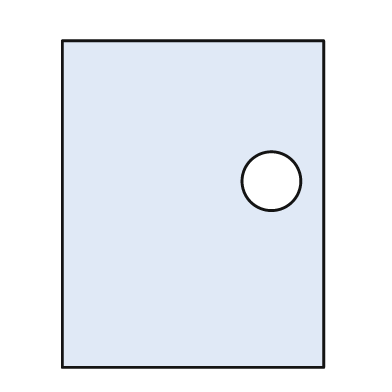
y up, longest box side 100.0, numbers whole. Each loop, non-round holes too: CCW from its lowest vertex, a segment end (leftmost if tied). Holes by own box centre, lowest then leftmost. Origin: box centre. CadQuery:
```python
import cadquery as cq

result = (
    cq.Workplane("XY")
    .moveTo(-40.0, -50.0)
    .lineTo(40.0, -50.0)
    .lineTo(40.0, 50.0)
    .lineTo(-40.0, 50.0)
    .close()
    .moveTo(24.0, 7.0)
    .circle(9.0)
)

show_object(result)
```